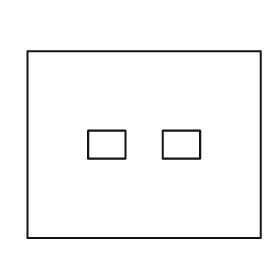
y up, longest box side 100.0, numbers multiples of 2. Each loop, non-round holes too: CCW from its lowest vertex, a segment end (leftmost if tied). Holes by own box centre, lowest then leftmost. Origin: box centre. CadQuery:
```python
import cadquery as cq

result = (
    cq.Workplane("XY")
    .moveTo(-50.0, -40.0)
    .lineTo(50.0, -40.0)
    .lineTo(50.0, 40.0)
    .lineTo(-50.0, 40.0)
    .close()
    .moveTo(-24.0, -6.0)
    .lineTo(-8.0, -6.0)
    .lineTo(-8.0, 6.0)
    .lineTo(-24.0, 6.0)
    .close()
    .moveTo(8.0, -6.0)
    .lineTo(24.0, -6.0)
    .lineTo(24.0, 6.0)
    .lineTo(8.0, 6.0)
    .close()
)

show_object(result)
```